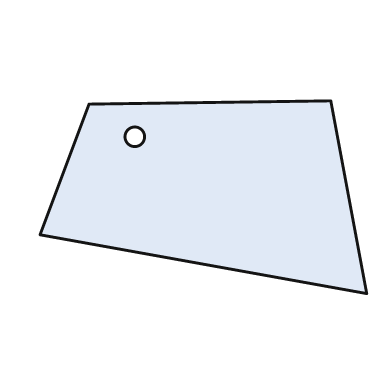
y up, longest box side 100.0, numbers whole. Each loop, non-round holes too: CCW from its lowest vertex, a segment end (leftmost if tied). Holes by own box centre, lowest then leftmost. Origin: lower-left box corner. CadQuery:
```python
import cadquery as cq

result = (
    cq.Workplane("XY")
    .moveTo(100.0, 0.0)
    .lineTo(89.0, 59.0)
    .lineTo(15.0, 58.0)
    .lineTo(0.0, 18.0)
    .close()
    .moveTo(29.0, 48.0)
    .circle(3.0)
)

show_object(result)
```